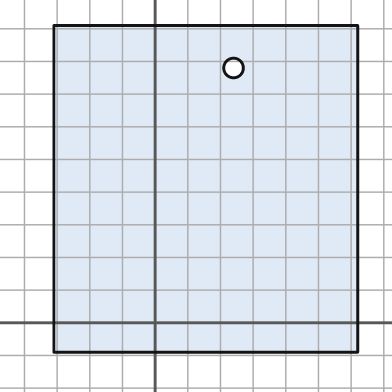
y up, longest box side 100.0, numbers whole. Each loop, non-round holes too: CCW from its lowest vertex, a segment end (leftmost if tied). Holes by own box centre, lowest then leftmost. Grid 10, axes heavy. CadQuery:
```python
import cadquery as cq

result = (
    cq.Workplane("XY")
    .moveTo(-31.0, -9.0)
    .lineTo(62.0, -9.0)
    .lineTo(62.0, 91.0)
    .lineTo(-31.0, 91.0)
    .close()
    .moveTo(24.0, 78.0)
    .circle(3.0)
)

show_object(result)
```